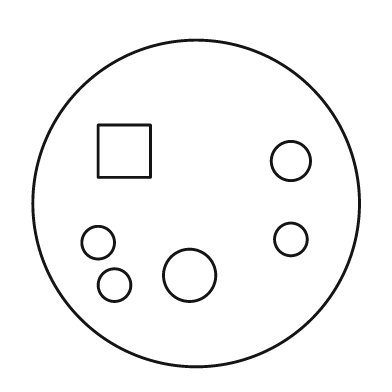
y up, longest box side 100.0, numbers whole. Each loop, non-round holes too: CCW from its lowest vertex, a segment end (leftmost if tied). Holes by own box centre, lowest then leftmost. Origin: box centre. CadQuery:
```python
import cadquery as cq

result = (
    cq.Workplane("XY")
    .moveTo(0.0, 0.0)
    .circle(50.0)
    .moveTo(-25.0, -25.0)
    .circle(5.0)
    .moveTo(-2.0, -22.0)
    .circle(8.0)
    .moveTo(-30.0, -12.0)
    .circle(5.0)
    .moveTo(29.0, -11.0)
    .circle(5.0)
    .moveTo(29.0, 13.0)
    .circle(6.0)
    .moveTo(-30.0, 8.0)
    .lineTo(-14.0, 8.0)
    .lineTo(-14.0, 24.0)
    .lineTo(-30.0, 24.0)
    .close()
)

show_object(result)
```